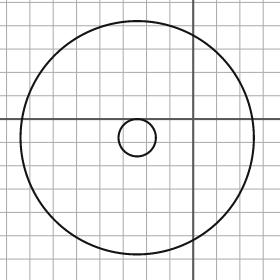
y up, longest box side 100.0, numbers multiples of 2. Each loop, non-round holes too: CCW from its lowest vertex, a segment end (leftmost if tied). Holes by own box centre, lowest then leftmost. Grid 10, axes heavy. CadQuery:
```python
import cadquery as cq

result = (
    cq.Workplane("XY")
    .moveTo(-24.0, -8.0)
    .circle(50.0)
    .moveTo(-24.0, -8.0)
    .circle(8.0)
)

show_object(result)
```